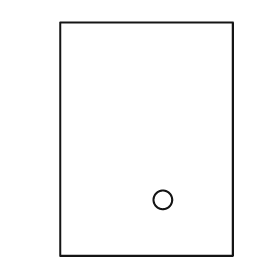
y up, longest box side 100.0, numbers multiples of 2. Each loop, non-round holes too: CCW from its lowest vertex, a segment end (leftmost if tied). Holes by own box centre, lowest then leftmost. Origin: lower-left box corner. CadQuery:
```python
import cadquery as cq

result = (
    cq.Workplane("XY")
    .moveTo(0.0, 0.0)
    .lineTo(74.0, 0.0)
    .lineTo(74.0, 100.0)
    .lineTo(0.0, 100.0)
    .close()
    .moveTo(44.0, 24.0)
    .circle(4.0)
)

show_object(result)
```